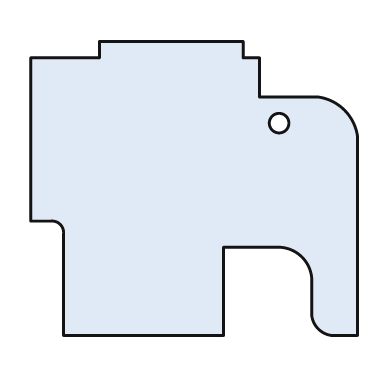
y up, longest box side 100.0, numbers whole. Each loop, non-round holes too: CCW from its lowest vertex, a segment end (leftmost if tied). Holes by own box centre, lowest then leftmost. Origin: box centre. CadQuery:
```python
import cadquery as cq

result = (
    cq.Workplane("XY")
    .moveTo(-40.0, -45.0)
    .lineTo(9.0, -45.0)
    .lineTo(9.0, -18.0)
    .lineTo(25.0, -18.0)
    .threePointArc((33.0, -21.0), (36.0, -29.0))
    .lineTo(36.0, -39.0)
    .threePointArc((38.0, -43.0), (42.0, -45.0))
    .lineTo(50.0, -45.0)
    .lineTo(50.0, 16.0)
    .threePointArc((46.0, 24.0), (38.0, 28.0))
    .lineTo(20.0, 28.0)
    .lineTo(20.0, 40.0)
    .lineTo(15.0, 40.0)
    .lineTo(15.0, 45.0)
    .lineTo(-29.0, 45.0)
    .lineTo(-29.0, 40.0)
    .lineTo(-50.0, 40.0)
    .lineTo(-50.0, -10.0)
    .lineTo(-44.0, -10.0)
    .threePointArc((-41.0, -11.0), (-40.0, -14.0))
    .close()
    .moveTo(26.0, 20.0)
    .circle(3.0)
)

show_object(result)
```